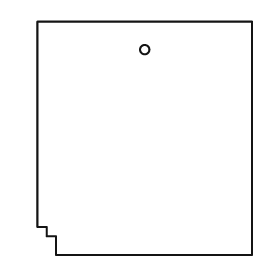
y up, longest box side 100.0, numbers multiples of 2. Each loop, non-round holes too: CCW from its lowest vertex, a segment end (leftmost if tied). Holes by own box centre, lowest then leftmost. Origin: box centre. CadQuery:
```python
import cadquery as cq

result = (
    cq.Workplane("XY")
    .moveTo(-38.0, -50.0)
    .lineTo(46.0, -50.0)
    .lineTo(46.0, 50.0)
    .lineTo(-46.0, 50.0)
    .lineTo(-46.0, -38.0)
    .lineTo(-42.0, -38.0)
    .lineTo(-42.0, -42.0)
    .lineTo(-38.0, -42.0)
    .close()
    .moveTo(0.0, 38.0)
    .circle(2.0)
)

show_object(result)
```